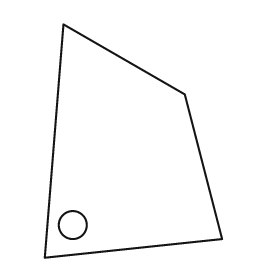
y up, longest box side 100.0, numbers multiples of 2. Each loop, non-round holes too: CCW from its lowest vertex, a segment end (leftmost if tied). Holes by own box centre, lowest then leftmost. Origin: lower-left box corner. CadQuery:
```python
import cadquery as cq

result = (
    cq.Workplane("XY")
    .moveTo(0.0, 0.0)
    .lineTo(76.0, 8.0)
    .lineTo(60.0, 70.0)
    .lineTo(8.0, 100.0)
    .close()
    .moveTo(12.0, 14.0)
    .circle(6.0)
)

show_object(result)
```